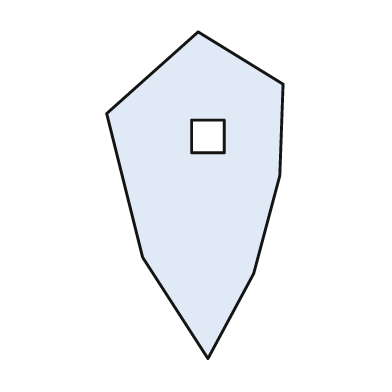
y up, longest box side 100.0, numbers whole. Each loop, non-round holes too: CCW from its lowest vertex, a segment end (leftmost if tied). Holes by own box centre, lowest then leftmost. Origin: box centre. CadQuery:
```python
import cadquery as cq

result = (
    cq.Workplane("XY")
    .moveTo(4.0, -50.0)
    .lineTo(18.0, -24.0)
    .lineTo(26.0, 6.0)
    .lineTo(27.0, 34.0)
    .lineTo(1.0, 50.0)
    .lineTo(-27.0, 25.0)
    .lineTo(-16.0, -19.0)
    .close()
    .moveTo(-1.0, 13.0)
    .lineTo(9.0, 13.0)
    .lineTo(9.0, 23.0)
    .lineTo(-1.0, 23.0)
    .close()
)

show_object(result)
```